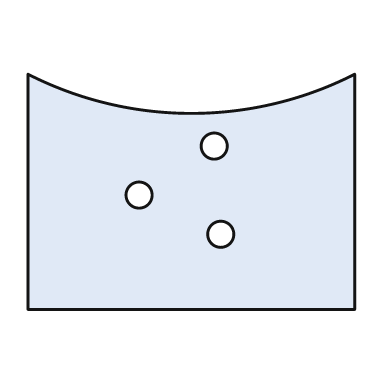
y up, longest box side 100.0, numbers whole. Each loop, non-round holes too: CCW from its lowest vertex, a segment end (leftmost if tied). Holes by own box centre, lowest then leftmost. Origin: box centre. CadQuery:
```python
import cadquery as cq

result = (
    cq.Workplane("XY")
    .moveTo(-50.0, -36.0)
    .lineTo(50.0, -36.0)
    .lineTo(50.0, 36.0)
    .threePointArc((0.0, 24.0), (-50.0, 36.0))
    .close()
    .moveTo(9.0, -13.0)
    .circle(4.0)
    .moveTo(-16.0, -1.0)
    .circle(4.0)
    .moveTo(7.0, 14.0)
    .circle(4.0)
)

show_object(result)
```